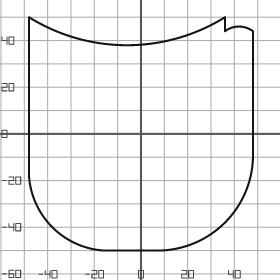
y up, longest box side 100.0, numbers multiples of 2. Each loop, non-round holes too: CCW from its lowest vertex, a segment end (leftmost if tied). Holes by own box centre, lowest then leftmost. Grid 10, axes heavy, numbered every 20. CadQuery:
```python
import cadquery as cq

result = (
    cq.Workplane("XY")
    .moveTo(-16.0, -50.0)
    .lineTo(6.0, -50.0)
    .threePointArc((36.0, -38.0), (48.0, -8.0))
    .lineTo(48.0, 44.0)
    .threePointArc((42.0, 46.0), (36.0, 44.0))
    .lineTo(36.0, 50.0)
    .threePointArc((-6.0, 38.0), (-48.0, 50.0))
    .lineTo(-48.0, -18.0)
    .threePointArc((-38.0, -40.0), (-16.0, -50.0))
    .close()
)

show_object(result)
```